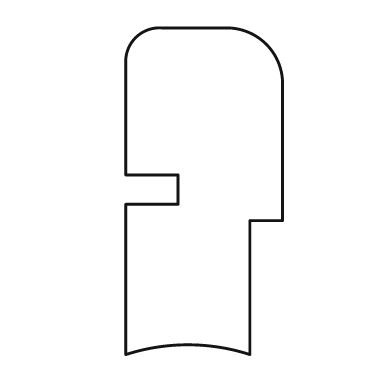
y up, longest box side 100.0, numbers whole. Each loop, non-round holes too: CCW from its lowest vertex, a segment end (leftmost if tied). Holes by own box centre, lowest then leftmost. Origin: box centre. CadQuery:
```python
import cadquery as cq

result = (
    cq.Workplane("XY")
    .moveTo(-24.0, -50.0)
    .threePointArc((-5.0, -47.0), (14.0, -50.0))
    .lineTo(14.0, -9.0)
    .lineTo(24.0, -9.0)
    .lineTo(24.0, 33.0)
    .threePointArc((19.0, 45.0), (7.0, 50.0))
    .lineTo(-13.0, 50.0)
    .threePointArc((-21.0, 47.0), (-24.0, 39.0))
    .lineTo(-24.0, 5.0)
    .lineTo(-8.0, 5.0)
    .lineTo(-8.0, -4.0)
    .lineTo(-24.0, -4.0)
    .close()
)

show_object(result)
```